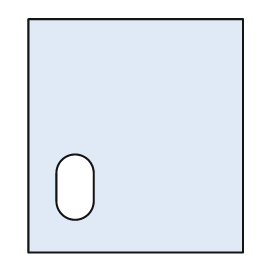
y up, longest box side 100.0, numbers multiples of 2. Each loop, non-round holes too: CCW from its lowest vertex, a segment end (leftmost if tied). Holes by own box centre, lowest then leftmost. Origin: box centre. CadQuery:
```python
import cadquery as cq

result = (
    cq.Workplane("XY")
    .moveTo(-46.0, -50.0)
    .lineTo(46.0, -50.0)
    .lineTo(46.0, 50.0)
    .lineTo(-46.0, 50.0)
    .close()
    .moveTo(-34.0, -28.0)
    .threePointArc((-26.0, -36.0), (-18.0, -28.0))
    .lineTo(-18.0, -16.0)
    .threePointArc((-26.0, -8.0), (-34.0, -16.0))
    .close()
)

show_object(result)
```